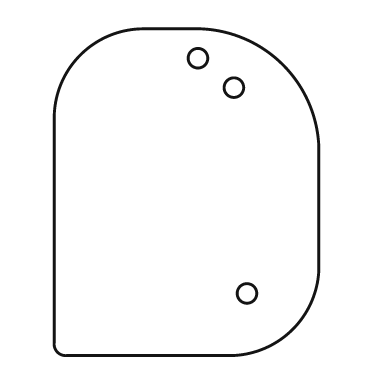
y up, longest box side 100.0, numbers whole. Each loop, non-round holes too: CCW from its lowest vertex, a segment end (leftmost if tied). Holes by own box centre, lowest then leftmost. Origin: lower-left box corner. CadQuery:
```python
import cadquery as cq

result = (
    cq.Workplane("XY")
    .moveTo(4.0, 0.0)
    .lineTo(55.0, 0.0)
    .threePointArc((73.0, 8.0), (81.0, 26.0))
    .lineTo(81.0, 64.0)
    .threePointArc((70.0, 89.0), (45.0, 100.0))
    .lineTo(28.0, 100.0)
    .threePointArc((8.0, 92.0), (0.0, 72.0))
    .lineTo(0.0, 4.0)
    .threePointArc((1.0, 1.0), (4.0, 0.0))
    .close()
    .moveTo(59.0, 19.0)
    .circle(3.0)
    .moveTo(55.0, 82.0)
    .circle(3.0)
    .moveTo(44.0, 91.0)
    .circle(3.0)
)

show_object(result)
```